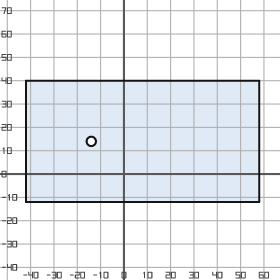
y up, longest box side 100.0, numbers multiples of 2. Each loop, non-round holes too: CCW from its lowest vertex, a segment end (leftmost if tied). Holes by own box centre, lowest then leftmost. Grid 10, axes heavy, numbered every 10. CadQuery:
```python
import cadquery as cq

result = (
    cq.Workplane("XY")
    .moveTo(-42.0, -12.0)
    .lineTo(58.0, -12.0)
    .lineTo(58.0, 40.0)
    .lineTo(-42.0, 40.0)
    .close()
    .moveTo(-14.0, 14.0)
    .circle(2.0)
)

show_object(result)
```